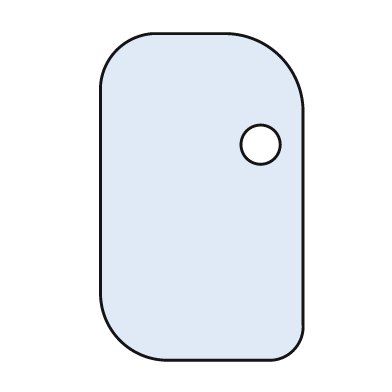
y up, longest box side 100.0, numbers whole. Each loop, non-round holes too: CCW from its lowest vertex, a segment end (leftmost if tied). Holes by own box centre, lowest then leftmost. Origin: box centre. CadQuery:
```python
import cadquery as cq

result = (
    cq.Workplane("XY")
    .moveTo(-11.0, -50.0)
    .lineTo(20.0, -50.0)
    .threePointArc((28.0, -47.0), (31.0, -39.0))
    .lineTo(31.0, 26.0)
    .threePointArc((24.0, 43.0), (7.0, 50.0))
    .lineTo(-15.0, 50.0)
    .threePointArc((-26.0, 45.0), (-31.0, 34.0))
    .lineTo(-31.0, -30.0)
    .threePointArc((-25.0, -44.0), (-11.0, -50.0))
    .close()
    .moveTo(18.0, 16.0)
    .circle(6.0)
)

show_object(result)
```